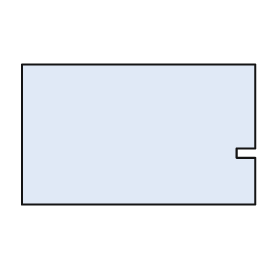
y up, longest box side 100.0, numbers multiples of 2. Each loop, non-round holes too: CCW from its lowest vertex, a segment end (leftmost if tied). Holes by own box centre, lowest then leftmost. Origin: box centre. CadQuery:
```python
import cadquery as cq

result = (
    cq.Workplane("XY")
    .moveTo(-50.0, -30.0)
    .lineTo(50.0, -30.0)
    .lineTo(50.0, -10.0)
    .lineTo(42.0, -10.0)
    .lineTo(42.0, -6.0)
    .lineTo(50.0, -6.0)
    .lineTo(50.0, 30.0)
    .lineTo(-50.0, 30.0)
    .close()
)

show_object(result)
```